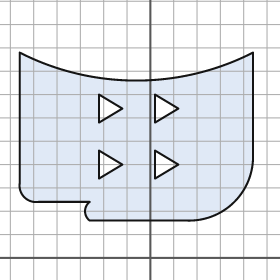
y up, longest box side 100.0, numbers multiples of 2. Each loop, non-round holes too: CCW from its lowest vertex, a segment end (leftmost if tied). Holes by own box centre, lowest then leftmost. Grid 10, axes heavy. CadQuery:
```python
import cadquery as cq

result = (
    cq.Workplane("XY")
    .moveTo(-26.0, 16.0)
    .lineTo(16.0, 16.0)
    .threePointArc((36.0, 24.0), (44.0, 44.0))
    .lineTo(44.0, 88.0)
    .threePointArc((-6.0, 76.0), (-56.0, 88.0))
    .lineTo(-56.0, 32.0)
    .threePointArc((-54.0, 26.0), (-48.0, 24.0))
    .lineTo(-26.0, 24.0)
    .threePointArc((-28.0, 20.0), (-26.0, 16.0))
    .close()
    .moveTo(-22.0, 34.0)
    .lineTo(-12.0, 40.0)
    .lineTo(-22.0, 46.0)
    .close()
    .moveTo(2.0, 34.0)
    .lineTo(12.0, 40.0)
    .lineTo(2.0, 46.0)
    .close()
    .moveTo(-22.0, 58.0)
    .lineTo(-12.0, 64.0)
    .lineTo(-22.0, 70.0)
    .close()
    .moveTo(2.0, 58.0)
    .lineTo(12.0, 64.0)
    .lineTo(2.0, 70.0)
    .close()
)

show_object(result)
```